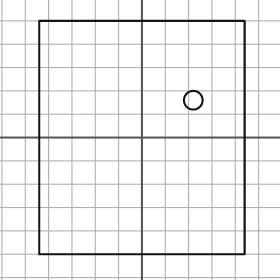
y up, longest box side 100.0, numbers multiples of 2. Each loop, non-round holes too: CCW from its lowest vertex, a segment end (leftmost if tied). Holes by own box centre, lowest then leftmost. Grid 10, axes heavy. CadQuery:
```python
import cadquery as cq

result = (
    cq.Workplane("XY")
    .moveTo(-44.0, -50.0)
    .lineTo(44.0, -50.0)
    .lineTo(44.0, 50.0)
    .lineTo(-44.0, 50.0)
    .close()
    .moveTo(22.0, 16.0)
    .circle(4.0)
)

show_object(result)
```